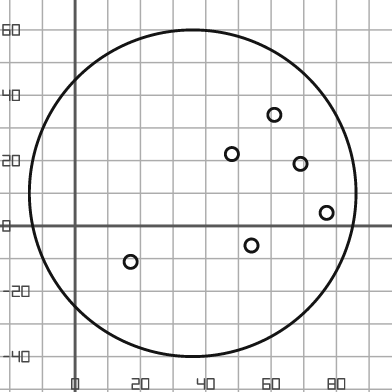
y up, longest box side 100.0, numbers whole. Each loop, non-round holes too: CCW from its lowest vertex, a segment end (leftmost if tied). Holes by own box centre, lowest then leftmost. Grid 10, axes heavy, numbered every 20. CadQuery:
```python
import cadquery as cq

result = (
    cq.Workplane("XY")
    .moveTo(36.0, 10.0)
    .circle(50.0)
    .moveTo(17.0, -11.0)
    .circle(2.0)
    .moveTo(54.0, -6.0)
    .circle(2.0)
    .moveTo(77.0, 4.0)
    .circle(2.0)
    .moveTo(69.0, 19.0)
    .circle(2.0)
    .moveTo(48.0, 22.0)
    .circle(2.0)
    .moveTo(61.0, 34.0)
    .circle(2.0)
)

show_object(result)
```